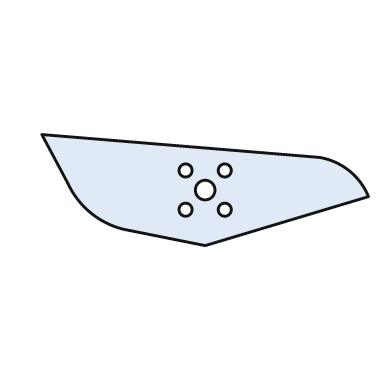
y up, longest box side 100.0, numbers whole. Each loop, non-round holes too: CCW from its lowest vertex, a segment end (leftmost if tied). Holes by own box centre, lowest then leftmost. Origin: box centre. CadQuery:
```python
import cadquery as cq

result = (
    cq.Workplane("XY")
    .moveTo(0.0, -17.0)
    .lineTo(50.0, -2.0)
    .threePointArc((44.0, 6.0), (35.0, 10.0))
    .lineTo(-50.0, 17.0)
    .lineTo(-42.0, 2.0)
    .threePointArc((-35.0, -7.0), (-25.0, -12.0))
    .close()
    .moveTo(-6.0, -6.0)
    .circle(2.0)
    .moveTo(6.0, -6.0)
    .circle(2.0)
    .moveTo(0.0, 0.0)
    .circle(3.0)
    .moveTo(-6.0, 6.0)
    .circle(2.0)
    .moveTo(6.0, 6.0)
    .circle(2.0)
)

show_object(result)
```